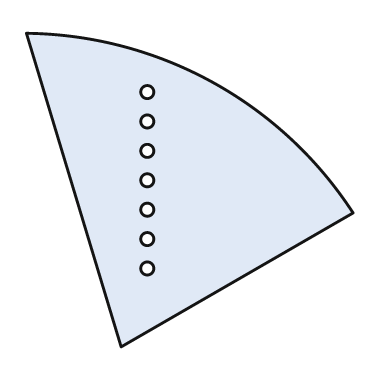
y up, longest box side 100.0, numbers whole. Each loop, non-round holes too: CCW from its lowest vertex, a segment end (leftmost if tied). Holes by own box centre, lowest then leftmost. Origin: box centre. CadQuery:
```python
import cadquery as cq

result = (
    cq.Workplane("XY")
    .moveTo(-21.0, -48.0)
    .lineTo(50.0, -7.0)
    .threePointArc((7.0, 33.0), (-50.0, 48.0))
    .close()
    .moveTo(-13.0, -24.0)
    .circle(2.0)
    .moveTo(-13.0, -15.0)
    .circle(2.0)
    .moveTo(-13.0, -6.0)
    .circle(2.0)
    .moveTo(-13.0, 3.0)
    .circle(2.0)
    .moveTo(-13.0, 12.0)
    .circle(2.0)
    .moveTo(-13.0, 21.0)
    .circle(2.0)
    .moveTo(-13.0, 30.0)
    .circle(2.0)
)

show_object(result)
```